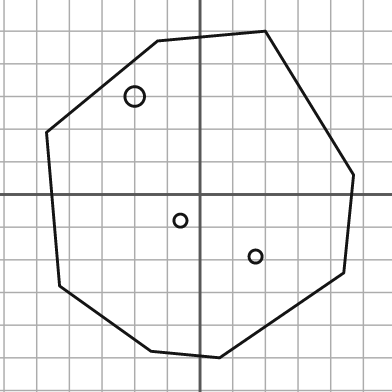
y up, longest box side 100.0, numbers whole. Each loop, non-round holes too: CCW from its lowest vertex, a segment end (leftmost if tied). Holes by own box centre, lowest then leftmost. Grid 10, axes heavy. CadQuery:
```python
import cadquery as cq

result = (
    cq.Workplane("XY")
    .moveTo(6.0, -50.0)
    .lineTo(44.0, -24.0)
    .lineTo(47.0, 6.0)
    .lineTo(20.0, 50.0)
    .lineTo(-13.0, 47.0)
    .lineTo(-47.0, 19.0)
    .lineTo(-43.0, -28.0)
    .lineTo(-15.0, -48.0)
    .close()
    .moveTo(17.0, -19.0)
    .circle(2.0)
    .moveTo(-6.0, -8.0)
    .circle(2.0)
    .moveTo(-20.0, 30.0)
    .circle(3.0)
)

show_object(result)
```